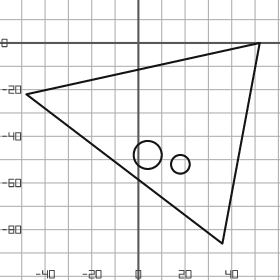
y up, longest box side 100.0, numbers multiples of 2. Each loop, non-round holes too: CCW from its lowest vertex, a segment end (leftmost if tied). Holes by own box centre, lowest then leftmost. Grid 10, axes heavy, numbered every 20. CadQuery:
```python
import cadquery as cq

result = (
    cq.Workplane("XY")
    .moveTo(36.0, -86.0)
    .lineTo(52.0, 0.0)
    .lineTo(-48.0, -22.0)
    .close()
    .moveTo(18.0, -52.0)
    .circle(4.0)
    .moveTo(4.0, -48.0)
    .circle(6.0)
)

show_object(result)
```